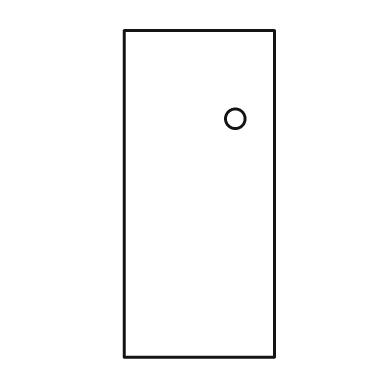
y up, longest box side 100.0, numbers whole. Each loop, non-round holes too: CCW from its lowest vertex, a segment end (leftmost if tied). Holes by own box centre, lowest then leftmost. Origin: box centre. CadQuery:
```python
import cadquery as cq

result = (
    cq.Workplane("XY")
    .moveTo(-23.0, -50.0)
    .lineTo(23.0, -50.0)
    .lineTo(23.0, 50.0)
    .lineTo(-23.0, 50.0)
    .close()
    .moveTo(11.0, 23.0)
    .circle(3.0)
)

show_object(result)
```